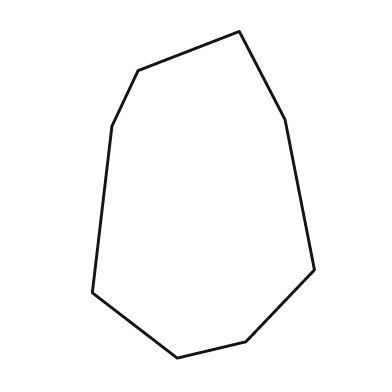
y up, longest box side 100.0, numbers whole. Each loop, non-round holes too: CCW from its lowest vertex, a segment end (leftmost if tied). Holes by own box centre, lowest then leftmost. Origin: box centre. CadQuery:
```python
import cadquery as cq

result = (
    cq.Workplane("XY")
    .moveTo(-8.0, -50.0)
    .lineTo(13.0, -45.0)
    .lineTo(34.0, -23.0)
    .lineTo(25.0, 23.0)
    .lineTo(11.0, 50.0)
    .lineTo(-20.0, 38.0)
    .lineTo(-28.0, 21.0)
    .lineTo(-34.0, -30.0)
    .close()
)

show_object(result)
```